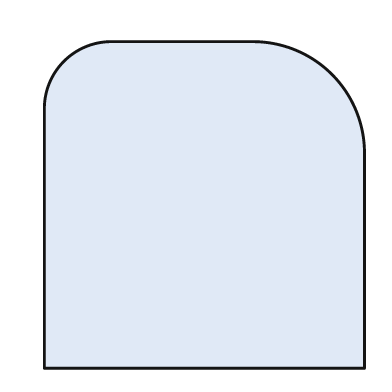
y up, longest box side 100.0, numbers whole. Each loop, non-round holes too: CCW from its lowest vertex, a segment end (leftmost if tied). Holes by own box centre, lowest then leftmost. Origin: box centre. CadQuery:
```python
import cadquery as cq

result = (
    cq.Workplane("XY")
    .moveTo(-49.0, -50.0)
    .lineTo(49.0, -50.0)
    .lineTo(49.0, 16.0)
    .threePointArc((39.0, 40.0), (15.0, 50.0))
    .lineTo(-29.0, 50.0)
    .threePointArc((-43.0, 44.0), (-49.0, 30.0))
    .close()
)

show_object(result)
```